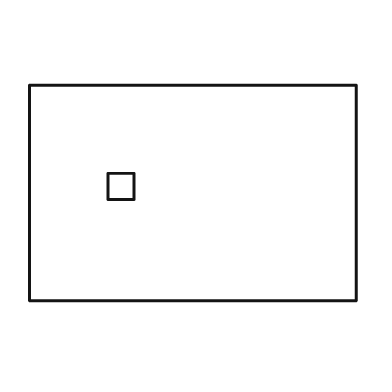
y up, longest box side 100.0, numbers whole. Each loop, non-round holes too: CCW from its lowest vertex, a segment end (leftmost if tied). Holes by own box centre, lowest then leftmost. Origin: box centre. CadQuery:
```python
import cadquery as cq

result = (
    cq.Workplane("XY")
    .moveTo(-50.0, -33.0)
    .lineTo(50.0, -33.0)
    .lineTo(50.0, 33.0)
    .lineTo(-50.0, 33.0)
    .close()
    .moveTo(-26.0, -2.0)
    .lineTo(-18.0, -2.0)
    .lineTo(-18.0, 6.0)
    .lineTo(-26.0, 6.0)
    .close()
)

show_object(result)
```